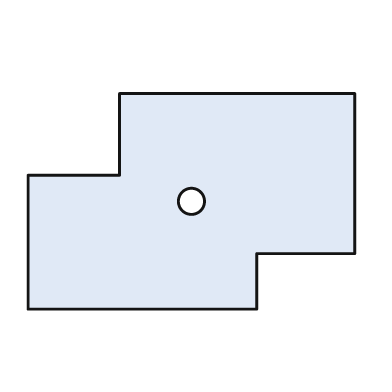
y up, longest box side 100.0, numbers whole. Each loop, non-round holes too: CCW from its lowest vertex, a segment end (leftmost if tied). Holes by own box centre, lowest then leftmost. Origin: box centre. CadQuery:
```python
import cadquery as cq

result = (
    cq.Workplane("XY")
    .moveTo(-50.0, -33.0)
    .lineTo(20.0, -33.0)
    .lineTo(20.0, -16.0)
    .lineTo(50.0, -16.0)
    .lineTo(50.0, 33.0)
    .lineTo(-22.0, 33.0)
    .lineTo(-22.0, 8.0)
    .lineTo(-50.0, 8.0)
    .close()
    .moveTo(0.0, 0.0)
    .circle(4.0)
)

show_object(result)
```